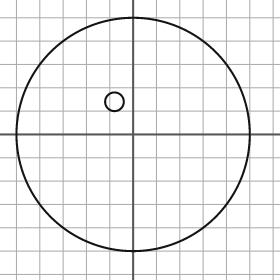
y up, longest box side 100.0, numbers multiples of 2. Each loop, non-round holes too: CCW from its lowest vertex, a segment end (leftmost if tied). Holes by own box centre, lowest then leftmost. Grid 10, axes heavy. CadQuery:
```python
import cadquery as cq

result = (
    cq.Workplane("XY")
    .moveTo(0.0, 0.0)
    .circle(50.0)
    .moveTo(-8.0, 14.0)
    .circle(4.0)
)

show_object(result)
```